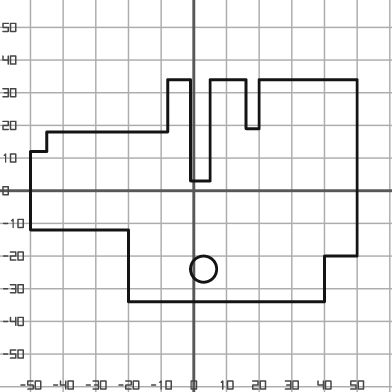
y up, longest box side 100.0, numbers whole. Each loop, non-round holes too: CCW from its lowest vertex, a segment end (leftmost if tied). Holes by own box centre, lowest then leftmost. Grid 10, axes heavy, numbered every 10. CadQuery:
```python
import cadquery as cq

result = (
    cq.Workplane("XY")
    .moveTo(-20.0, -34.0)
    .lineTo(40.0, -34.0)
    .lineTo(40.0, -20.0)
    .lineTo(50.0, -20.0)
    .lineTo(50.0, 34.0)
    .lineTo(20.0, 34.0)
    .lineTo(20.0, 19.0)
    .lineTo(16.0, 19.0)
    .lineTo(16.0, 34.0)
    .lineTo(5.0, 34.0)
    .lineTo(5.0, 3.0)
    .lineTo(-1.0, 3.0)
    .lineTo(-1.0, 34.0)
    .lineTo(-8.0, 34.0)
    .lineTo(-8.0, 18.0)
    .lineTo(-45.0, 18.0)
    .lineTo(-45.0, 12.0)
    .lineTo(-50.0, 12.0)
    .lineTo(-50.0, -12.0)
    .lineTo(-20.0, -12.0)
    .close()
    .moveTo(3.0, -24.0)
    .circle(4.0)
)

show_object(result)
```